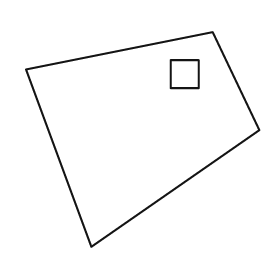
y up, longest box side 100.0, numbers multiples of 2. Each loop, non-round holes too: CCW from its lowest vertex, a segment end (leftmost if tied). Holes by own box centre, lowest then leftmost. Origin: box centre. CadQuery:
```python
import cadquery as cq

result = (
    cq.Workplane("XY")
    .moveTo(-22.0, -46.0)
    .lineTo(50.0, 4.0)
    .lineTo(30.0, 46.0)
    .lineTo(-50.0, 30.0)
    .close()
    .moveTo(12.0, 22.0)
    .lineTo(24.0, 22.0)
    .lineTo(24.0, 34.0)
    .lineTo(12.0, 34.0)
    .close()
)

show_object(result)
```